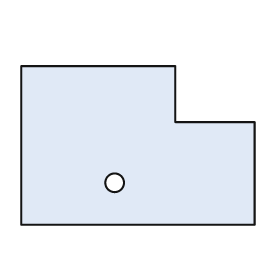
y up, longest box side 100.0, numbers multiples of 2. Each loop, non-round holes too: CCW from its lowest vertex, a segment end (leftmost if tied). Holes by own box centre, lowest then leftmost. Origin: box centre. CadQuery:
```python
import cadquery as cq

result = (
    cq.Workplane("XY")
    .moveTo(-50.0, -34.0)
    .lineTo(50.0, -34.0)
    .lineTo(50.0, 10.0)
    .lineTo(16.0, 10.0)
    .lineTo(16.0, 34.0)
    .lineTo(-50.0, 34.0)
    .close()
    .moveTo(-10.0, -16.0)
    .circle(4.0)
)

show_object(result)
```